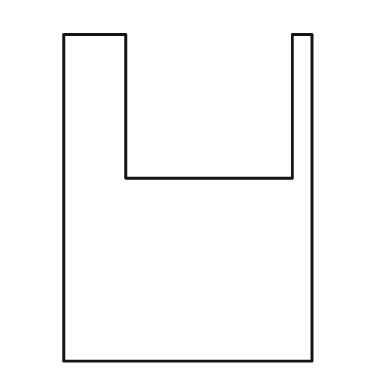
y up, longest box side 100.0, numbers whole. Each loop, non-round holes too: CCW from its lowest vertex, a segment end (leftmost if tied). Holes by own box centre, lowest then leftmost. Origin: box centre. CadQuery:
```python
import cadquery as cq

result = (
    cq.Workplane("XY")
    .moveTo(-38.0, -50.0)
    .lineTo(38.0, -50.0)
    .lineTo(38.0, 50.0)
    .lineTo(32.0, 50.0)
    .lineTo(32.0, 6.0)
    .lineTo(-19.0, 6.0)
    .lineTo(-19.0, 50.0)
    .lineTo(-38.0, 50.0)
    .close()
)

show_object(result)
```